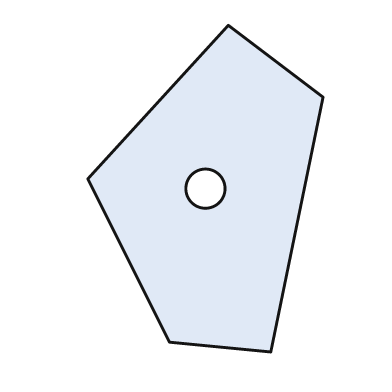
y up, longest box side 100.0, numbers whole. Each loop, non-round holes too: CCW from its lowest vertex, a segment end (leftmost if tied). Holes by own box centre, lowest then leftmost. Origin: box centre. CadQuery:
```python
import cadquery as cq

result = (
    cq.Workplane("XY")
    .moveTo(20.0, -50.0)
    .lineTo(36.0, 28.0)
    .lineTo(7.0, 50.0)
    .lineTo(-36.0, 3.0)
    .lineTo(-11.0, -47.0)
    .close()
    .moveTo(0.0, 0.0)
    .circle(6.0)
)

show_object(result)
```